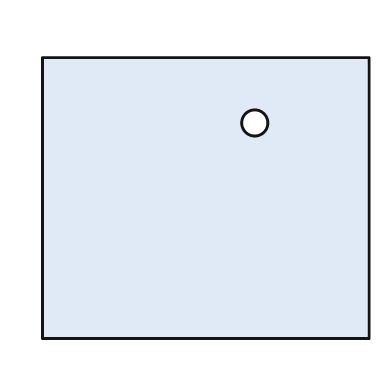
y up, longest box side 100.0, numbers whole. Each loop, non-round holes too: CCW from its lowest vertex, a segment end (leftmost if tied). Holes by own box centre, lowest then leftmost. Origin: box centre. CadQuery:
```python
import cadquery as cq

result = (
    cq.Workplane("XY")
    .moveTo(-50.0, -43.0)
    .lineTo(50.0, -43.0)
    .lineTo(50.0, 43.0)
    .lineTo(-50.0, 43.0)
    .close()
    .moveTo(15.0, 23.0)
    .circle(4.0)
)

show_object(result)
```